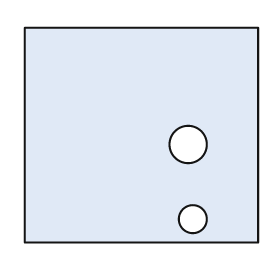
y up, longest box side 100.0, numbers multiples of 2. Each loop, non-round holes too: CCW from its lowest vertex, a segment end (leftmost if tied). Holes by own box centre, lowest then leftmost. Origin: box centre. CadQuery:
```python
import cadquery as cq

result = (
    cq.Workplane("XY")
    .moveTo(-50.0, -46.0)
    .lineTo(50.0, -46.0)
    .lineTo(50.0, 46.0)
    .lineTo(-50.0, 46.0)
    .close()
    .moveTo(22.0, -36.0)
    .circle(6.0)
    .moveTo(20.0, -4.0)
    .circle(8.0)
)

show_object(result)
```